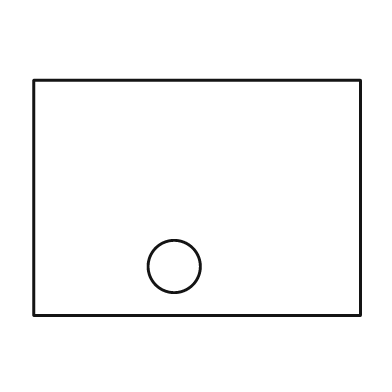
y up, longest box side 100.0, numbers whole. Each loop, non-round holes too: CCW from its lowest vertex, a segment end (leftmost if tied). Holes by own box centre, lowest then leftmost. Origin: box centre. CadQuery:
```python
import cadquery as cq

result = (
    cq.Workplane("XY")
    .moveTo(-50.0, -36.0)
    .lineTo(50.0, -36.0)
    .lineTo(50.0, 36.0)
    .lineTo(-50.0, 36.0)
    .close()
    .moveTo(-7.0, -21.0)
    .circle(8.0)
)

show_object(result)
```